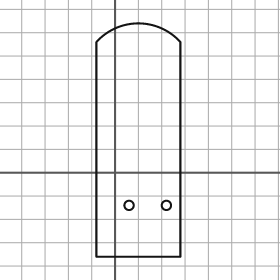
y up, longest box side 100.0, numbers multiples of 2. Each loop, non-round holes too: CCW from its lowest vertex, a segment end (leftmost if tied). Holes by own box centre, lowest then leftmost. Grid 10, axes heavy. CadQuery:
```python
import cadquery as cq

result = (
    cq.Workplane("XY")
    .moveTo(-8.0, -36.0)
    .lineTo(28.0, -36.0)
    .lineTo(28.0, 56.0)
    .threePointArc((10.0, 64.0), (-8.0, 56.0))
    .close()
    .moveTo(6.0, -14.0)
    .circle(2.0)
    .moveTo(22.0, -14.0)
    .circle(2.0)
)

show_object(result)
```